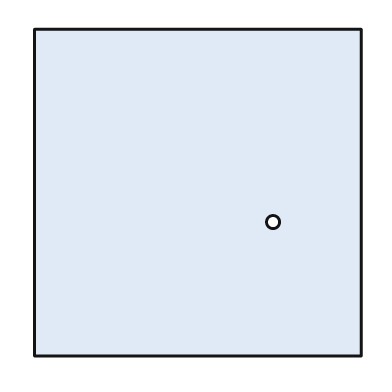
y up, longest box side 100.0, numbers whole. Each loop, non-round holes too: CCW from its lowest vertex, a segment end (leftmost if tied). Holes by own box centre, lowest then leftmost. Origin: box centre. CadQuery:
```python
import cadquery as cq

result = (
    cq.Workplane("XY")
    .moveTo(-50.0, -50.0)
    .lineTo(50.0, -50.0)
    .lineTo(50.0, 50.0)
    .lineTo(-50.0, 50.0)
    .close()
    .moveTo(23.0, -9.0)
    .circle(2.0)
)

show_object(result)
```